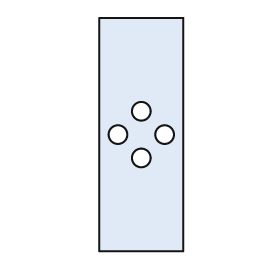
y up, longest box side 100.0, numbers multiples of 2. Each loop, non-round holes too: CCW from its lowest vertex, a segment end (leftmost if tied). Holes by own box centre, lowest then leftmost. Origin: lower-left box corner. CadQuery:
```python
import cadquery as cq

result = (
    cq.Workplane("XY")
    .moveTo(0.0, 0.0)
    .lineTo(36.0, 0.0)
    .lineTo(36.0, 100.0)
    .lineTo(0.0, 100.0)
    .close()
    .moveTo(18.0, 40.0)
    .circle(4.0)
    .moveTo(8.0, 50.0)
    .circle(4.0)
    .moveTo(28.0, 50.0)
    .circle(4.0)
    .moveTo(18.0, 60.0)
    .circle(4.0)
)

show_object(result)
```